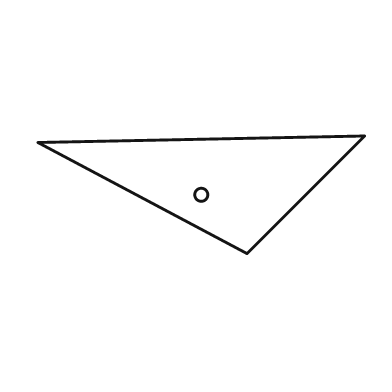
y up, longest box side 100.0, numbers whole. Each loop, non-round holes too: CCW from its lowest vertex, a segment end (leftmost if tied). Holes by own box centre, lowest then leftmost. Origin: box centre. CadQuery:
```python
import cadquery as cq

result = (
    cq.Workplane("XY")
    .moveTo(14.0, -18.0)
    .lineTo(50.0, 18.0)
    .lineTo(-50.0, 16.0)
    .close()
    .moveTo(0.0, 0.0)
    .circle(2.0)
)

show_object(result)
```